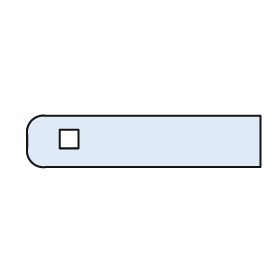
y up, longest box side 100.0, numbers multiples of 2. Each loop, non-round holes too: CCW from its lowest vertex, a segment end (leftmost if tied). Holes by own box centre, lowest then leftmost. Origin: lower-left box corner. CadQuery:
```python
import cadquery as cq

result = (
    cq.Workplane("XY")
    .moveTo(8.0, 0.0)
    .lineTo(100.0, 0.0)
    .lineTo(100.0, 22.0)
    .lineTo(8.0, 22.0)
    .threePointArc((2.0, 20.0), (0.0, 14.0))
    .lineTo(0.0, 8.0)
    .threePointArc((2.0, 2.0), (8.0, 0.0))
    .close()
    .moveTo(14.0, 8.0)
    .lineTo(22.0, 8.0)
    .lineTo(22.0, 16.0)
    .lineTo(14.0, 16.0)
    .close()
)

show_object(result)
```